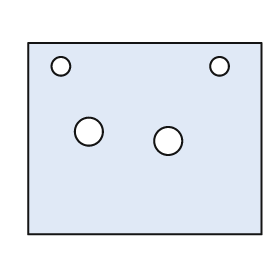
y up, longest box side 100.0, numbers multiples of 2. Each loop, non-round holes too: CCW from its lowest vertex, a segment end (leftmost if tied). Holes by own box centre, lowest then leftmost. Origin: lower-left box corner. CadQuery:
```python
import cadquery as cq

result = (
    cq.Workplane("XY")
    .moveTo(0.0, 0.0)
    .lineTo(100.0, 0.0)
    .lineTo(100.0, 82.0)
    .lineTo(0.0, 82.0)
    .close()
    .moveTo(60.0, 40.0)
    .circle(6.0)
    .moveTo(26.0, 44.0)
    .circle(6.0)
    .moveTo(14.0, 72.0)
    .circle(4.0)
    .moveTo(82.0, 72.0)
    .circle(4.0)
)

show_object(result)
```